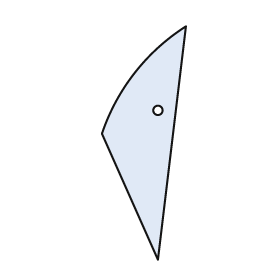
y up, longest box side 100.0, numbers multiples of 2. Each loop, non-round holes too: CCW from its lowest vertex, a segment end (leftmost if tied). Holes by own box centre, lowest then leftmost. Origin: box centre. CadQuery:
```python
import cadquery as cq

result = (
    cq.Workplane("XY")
    .moveTo(6.0, -50.0)
    .lineTo(18.0, 50.0)
    .threePointArc((-4.0, 30.0), (-18.0, 4.0))
    .close()
    .moveTo(6.0, 14.0)
    .circle(2.0)
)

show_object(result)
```